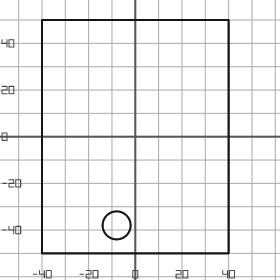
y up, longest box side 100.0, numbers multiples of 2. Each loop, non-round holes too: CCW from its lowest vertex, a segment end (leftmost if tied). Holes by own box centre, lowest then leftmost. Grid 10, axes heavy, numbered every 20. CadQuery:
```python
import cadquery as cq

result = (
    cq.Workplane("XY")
    .moveTo(-40.0, -50.0)
    .lineTo(40.0, -50.0)
    .lineTo(40.0, 50.0)
    .lineTo(-40.0, 50.0)
    .close()
    .moveTo(-8.0, -38.0)
    .circle(6.0)
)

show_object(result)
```